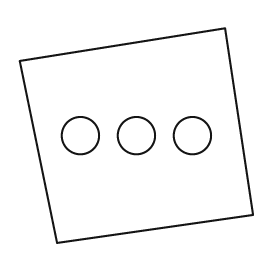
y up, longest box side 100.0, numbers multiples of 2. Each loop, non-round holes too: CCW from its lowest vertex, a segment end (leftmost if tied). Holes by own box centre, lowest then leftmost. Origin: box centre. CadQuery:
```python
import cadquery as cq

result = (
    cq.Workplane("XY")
    .moveTo(-34.0, -46.0)
    .lineTo(50.0, -34.0)
    .lineTo(38.0, 46.0)
    .lineTo(-50.0, 32.0)
    .close()
    .moveTo(-24.0, 0.0)
    .circle(8.0)
    .moveTo(0.0, 0.0)
    .circle(8.0)
    .moveTo(24.0, 0.0)
    .circle(8.0)
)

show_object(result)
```